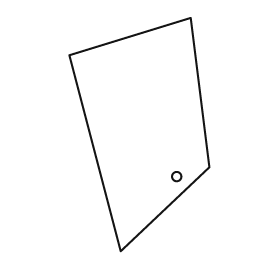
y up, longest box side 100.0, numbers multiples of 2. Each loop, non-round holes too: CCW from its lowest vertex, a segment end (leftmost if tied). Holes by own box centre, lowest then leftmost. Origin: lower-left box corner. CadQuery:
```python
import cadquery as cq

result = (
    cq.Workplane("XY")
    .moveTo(22.0, 0.0)
    .lineTo(60.0, 36.0)
    .lineTo(52.0, 100.0)
    .lineTo(0.0, 84.0)
    .close()
    .moveTo(46.0, 32.0)
    .circle(2.0)
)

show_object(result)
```